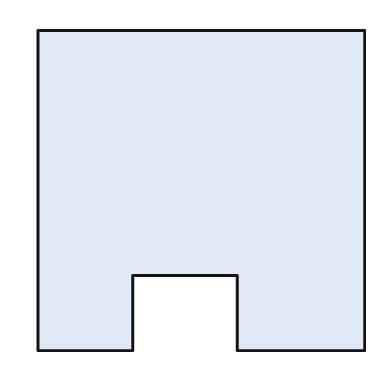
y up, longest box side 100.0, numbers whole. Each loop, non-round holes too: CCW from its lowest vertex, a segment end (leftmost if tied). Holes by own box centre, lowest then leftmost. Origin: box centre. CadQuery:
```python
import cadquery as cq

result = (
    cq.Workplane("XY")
    .moveTo(-50.0, -49.0)
    .lineTo(-21.0, -49.0)
    .lineTo(-21.0, -26.0)
    .lineTo(11.0, -26.0)
    .lineTo(11.0, -49.0)
    .lineTo(50.0, -49.0)
    .lineTo(50.0, 49.0)
    .lineTo(-50.0, 49.0)
    .close()
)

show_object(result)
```